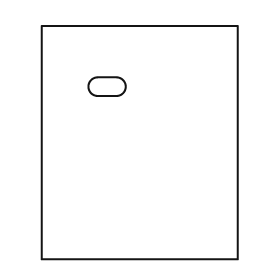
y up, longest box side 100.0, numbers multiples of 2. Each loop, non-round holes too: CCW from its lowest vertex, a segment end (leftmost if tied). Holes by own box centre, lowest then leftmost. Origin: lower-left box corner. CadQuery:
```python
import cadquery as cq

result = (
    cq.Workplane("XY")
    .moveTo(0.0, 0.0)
    .lineTo(84.0, 0.0)
    .lineTo(84.0, 100.0)
    .lineTo(0.0, 100.0)
    .close()
    .moveTo(24.0, 70.0)
    .lineTo(32.0, 70.0)
    .threePointArc((36.0, 74.0), (32.0, 78.0))
    .lineTo(24.0, 78.0)
    .threePointArc((20.0, 74.0), (24.0, 70.0))
    .close()
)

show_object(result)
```